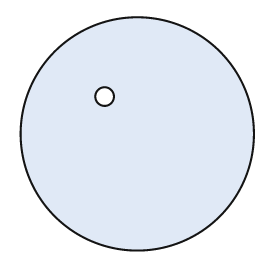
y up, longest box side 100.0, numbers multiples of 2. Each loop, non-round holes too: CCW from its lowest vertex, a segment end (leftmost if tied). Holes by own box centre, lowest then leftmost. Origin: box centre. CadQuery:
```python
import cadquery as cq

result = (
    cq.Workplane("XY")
    .moveTo(0.0, 0.0)
    .circle(50.0)
    .moveTo(-14.0, 16.0)
    .circle(4.0)
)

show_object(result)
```